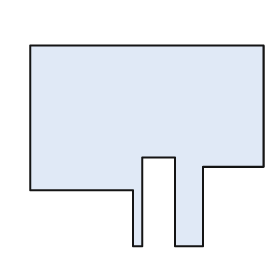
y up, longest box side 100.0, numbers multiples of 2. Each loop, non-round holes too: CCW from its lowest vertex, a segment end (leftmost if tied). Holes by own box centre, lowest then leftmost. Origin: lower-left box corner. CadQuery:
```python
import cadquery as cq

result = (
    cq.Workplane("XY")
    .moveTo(44.0, 0.0)
    .lineTo(48.0, 0.0)
    .lineTo(48.0, 38.0)
    .lineTo(62.0, 38.0)
    .lineTo(62.0, 0.0)
    .lineTo(74.0, 0.0)
    .lineTo(74.0, 34.0)
    .lineTo(100.0, 34.0)
    .lineTo(100.0, 86.0)
    .lineTo(0.0, 86.0)
    .lineTo(0.0, 24.0)
    .lineTo(44.0, 24.0)
    .close()
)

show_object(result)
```